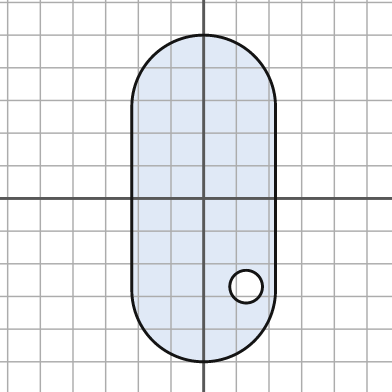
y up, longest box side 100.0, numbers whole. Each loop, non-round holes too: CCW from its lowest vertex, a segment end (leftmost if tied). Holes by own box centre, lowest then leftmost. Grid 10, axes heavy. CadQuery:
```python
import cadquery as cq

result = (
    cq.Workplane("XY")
    .moveTo(-22.0, -28.0)
    .threePointArc((0.0, -50.0), (22.0, -28.0))
    .lineTo(22.0, 28.0)
    .threePointArc((0.0, 50.0), (-22.0, 28.0))
    .close()
    .moveTo(13.0, -27.0)
    .circle(5.0)
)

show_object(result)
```